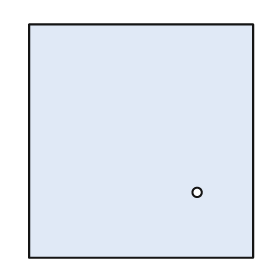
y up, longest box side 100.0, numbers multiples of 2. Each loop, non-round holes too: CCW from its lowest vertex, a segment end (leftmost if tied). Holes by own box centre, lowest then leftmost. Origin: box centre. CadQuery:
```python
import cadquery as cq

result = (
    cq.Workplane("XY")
    .moveTo(-48.0, -50.0)
    .lineTo(48.0, -50.0)
    .lineTo(48.0, 50.0)
    .lineTo(-48.0, 50.0)
    .close()
    .moveTo(24.0, -22.0)
    .circle(2.0)
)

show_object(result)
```